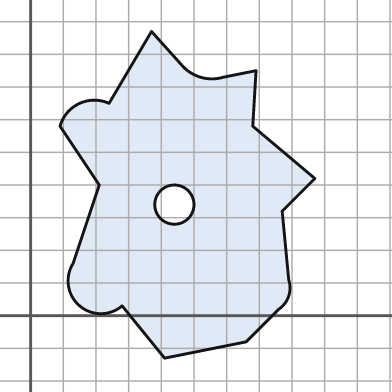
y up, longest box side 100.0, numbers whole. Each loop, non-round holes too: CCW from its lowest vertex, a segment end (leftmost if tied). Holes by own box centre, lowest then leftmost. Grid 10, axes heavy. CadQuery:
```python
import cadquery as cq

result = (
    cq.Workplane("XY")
    .moveTo(41.0, -13.0)
    .lineTo(66.0, -8.0)
    .lineTo(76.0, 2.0)
    .threePointArc((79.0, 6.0), (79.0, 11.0))
    .lineTo(77.0, 32.0)
    .lineTo(87.0, 42.0)
    .lineTo(68.0, 58.0)
    .lineTo(69.0, 75.0)
    .lineTo(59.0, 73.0)
    .threePointArc((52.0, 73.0), (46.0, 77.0))
    .lineTo(37.0, 87.0)
    .lineTo(24.0, 65.0)
    .threePointArc((15.0, 65.0), (9.0, 58.0))
    .lineTo(21.0, 40.0)
    .lineTo(13.0, 16.0)
    .threePointArc((15.0, 3.0), (28.0, 3.0))
    .close()
    .moveTo(44.0, 34.0)
    .circle(6.0)
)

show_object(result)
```